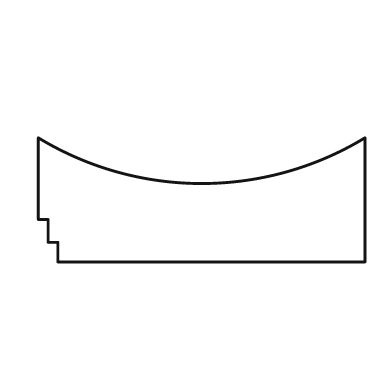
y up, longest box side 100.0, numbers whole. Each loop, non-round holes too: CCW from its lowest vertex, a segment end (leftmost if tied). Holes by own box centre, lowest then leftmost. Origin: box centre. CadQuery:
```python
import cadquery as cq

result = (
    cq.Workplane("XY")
    .moveTo(-44.0, -19.0)
    .lineTo(50.0, -19.0)
    .lineTo(50.0, 19.0)
    .threePointArc((0.0, 5.0), (-50.0, 19.0))
    .lineTo(-50.0, -6.0)
    .lineTo(-47.0, -6.0)
    .lineTo(-47.0, -13.0)
    .lineTo(-44.0, -13.0)
    .close()
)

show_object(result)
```